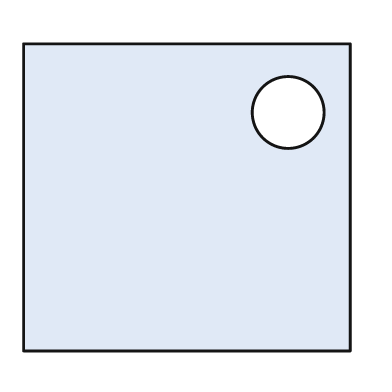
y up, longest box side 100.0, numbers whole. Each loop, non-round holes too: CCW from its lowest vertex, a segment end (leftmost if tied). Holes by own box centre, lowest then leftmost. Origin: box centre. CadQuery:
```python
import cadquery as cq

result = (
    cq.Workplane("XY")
    .moveTo(-50.0, -47.0)
    .lineTo(50.0, -47.0)
    .lineTo(50.0, 47.0)
    .lineTo(-50.0, 47.0)
    .close()
    .moveTo(31.0, 26.0)
    .circle(11.0)
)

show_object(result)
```